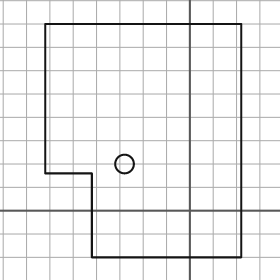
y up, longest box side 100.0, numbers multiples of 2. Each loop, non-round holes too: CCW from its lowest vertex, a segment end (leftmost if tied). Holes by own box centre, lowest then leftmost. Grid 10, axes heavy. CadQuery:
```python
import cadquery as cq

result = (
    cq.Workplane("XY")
    .moveTo(-42.0, -20.0)
    .lineTo(22.0, -20.0)
    .lineTo(22.0, 80.0)
    .lineTo(-62.0, 80.0)
    .lineTo(-62.0, 16.0)
    .lineTo(-42.0, 16.0)
    .close()
    .moveTo(-28.0, 20.0)
    .circle(4.0)
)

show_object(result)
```